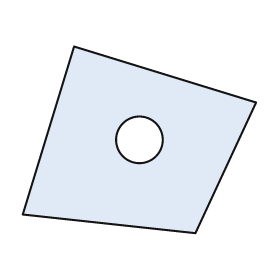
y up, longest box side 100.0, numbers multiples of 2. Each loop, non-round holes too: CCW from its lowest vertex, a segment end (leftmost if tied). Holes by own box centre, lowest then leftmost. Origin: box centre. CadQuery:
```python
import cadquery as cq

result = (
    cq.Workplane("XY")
    .moveTo(24.0, -40.0)
    .lineTo(50.0, 16.0)
    .lineTo(-28.0, 40.0)
    .lineTo(-50.0, -32.0)
    .close()
    .moveTo(0.0, 0.0)
    .circle(10.0)
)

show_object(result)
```